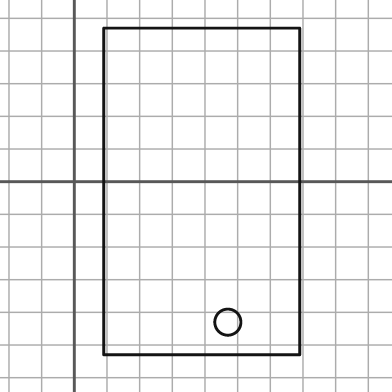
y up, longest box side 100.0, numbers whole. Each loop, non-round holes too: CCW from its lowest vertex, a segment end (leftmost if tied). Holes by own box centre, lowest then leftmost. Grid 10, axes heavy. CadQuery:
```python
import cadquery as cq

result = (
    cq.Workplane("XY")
    .moveTo(9.0, -53.0)
    .lineTo(69.0, -53.0)
    .lineTo(69.0, 47.0)
    .lineTo(9.0, 47.0)
    .close()
    .moveTo(47.0, -43.0)
    .circle(4.0)
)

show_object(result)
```